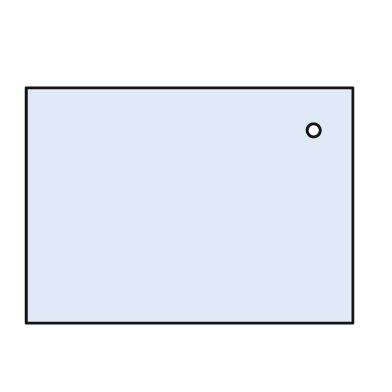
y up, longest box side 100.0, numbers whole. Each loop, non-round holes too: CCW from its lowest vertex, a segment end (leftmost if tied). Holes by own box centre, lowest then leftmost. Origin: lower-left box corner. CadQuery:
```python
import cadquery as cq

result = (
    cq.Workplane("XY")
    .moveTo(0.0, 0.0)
    .lineTo(100.0, 0.0)
    .lineTo(100.0, 72.0)
    .lineTo(0.0, 72.0)
    .close()
    .moveTo(88.0, 59.0)
    .circle(2.0)
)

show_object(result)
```